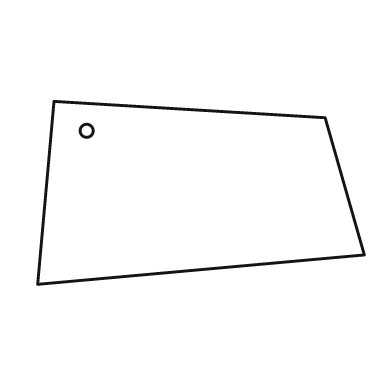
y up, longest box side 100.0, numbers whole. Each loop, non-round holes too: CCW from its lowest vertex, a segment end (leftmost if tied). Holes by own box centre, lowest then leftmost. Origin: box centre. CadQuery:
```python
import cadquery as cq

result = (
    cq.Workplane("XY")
    .moveTo(-50.0, -28.0)
    .lineTo(50.0, -19.0)
    .lineTo(38.0, 23.0)
    .lineTo(-45.0, 28.0)
    .close()
    .moveTo(-35.0, 19.0)
    .circle(2.0)
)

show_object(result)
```